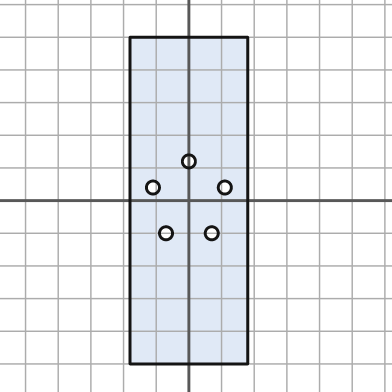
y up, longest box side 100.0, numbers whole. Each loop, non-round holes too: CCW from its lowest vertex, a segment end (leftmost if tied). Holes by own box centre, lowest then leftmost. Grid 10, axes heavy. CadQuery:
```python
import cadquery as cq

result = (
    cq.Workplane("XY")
    .moveTo(-18.0, -50.0)
    .lineTo(18.0, -50.0)
    .lineTo(18.0, 50.0)
    .lineTo(-18.0, 50.0)
    .close()
    .moveTo(-7.0, -10.0)
    .circle(2.0)
    .moveTo(7.0, -10.0)
    .circle(2.0)
    .moveTo(-11.0, 4.0)
    .circle(2.0)
    .moveTo(11.0, 4.0)
    .circle(2.0)
    .moveTo(0.0, 12.0)
    .circle(2.0)
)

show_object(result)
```